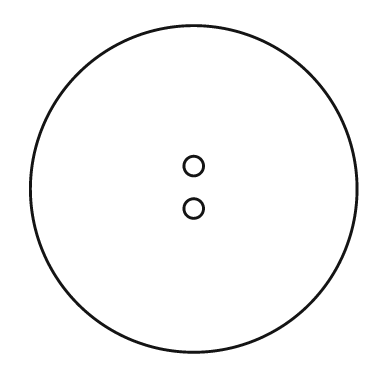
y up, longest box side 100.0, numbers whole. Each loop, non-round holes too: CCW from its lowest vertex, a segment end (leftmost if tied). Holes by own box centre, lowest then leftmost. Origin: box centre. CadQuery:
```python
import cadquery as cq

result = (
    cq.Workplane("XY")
    .moveTo(0.0, 0.0)
    .circle(50.0)
    .moveTo(0.0, -6.0)
    .circle(3.0)
    .moveTo(0.0, 7.0)
    .circle(3.0)
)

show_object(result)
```